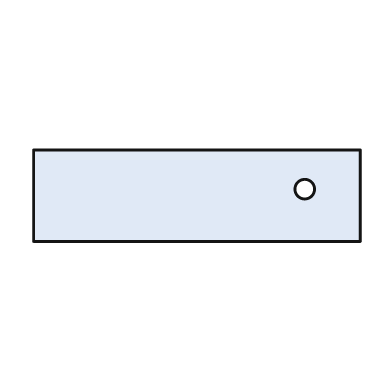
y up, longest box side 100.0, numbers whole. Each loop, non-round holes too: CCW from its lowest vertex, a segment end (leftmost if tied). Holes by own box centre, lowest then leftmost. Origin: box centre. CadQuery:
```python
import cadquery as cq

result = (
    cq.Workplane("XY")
    .moveTo(-50.0, -14.0)
    .lineTo(50.0, -14.0)
    .lineTo(50.0, 14.0)
    .lineTo(-50.0, 14.0)
    .close()
    .moveTo(33.0, 2.0)
    .circle(3.0)
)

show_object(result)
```